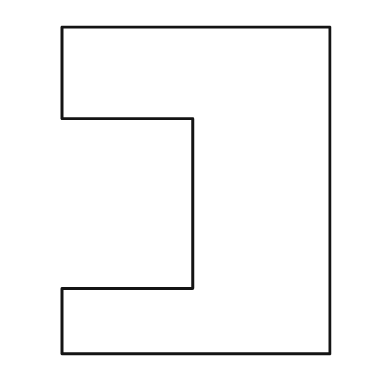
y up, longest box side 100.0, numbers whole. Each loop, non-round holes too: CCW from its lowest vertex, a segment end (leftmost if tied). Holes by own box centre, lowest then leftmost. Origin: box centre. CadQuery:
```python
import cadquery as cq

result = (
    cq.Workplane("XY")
    .moveTo(-41.0, -50.0)
    .lineTo(41.0, -50.0)
    .lineTo(41.0, 50.0)
    .lineTo(-41.0, 50.0)
    .lineTo(-41.0, 22.0)
    .lineTo(-1.0, 22.0)
    .lineTo(-1.0, -30.0)
    .lineTo(-41.0, -30.0)
    .close()
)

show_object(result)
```